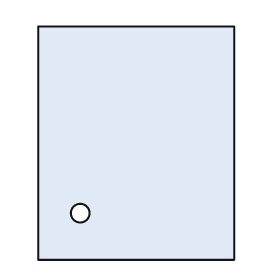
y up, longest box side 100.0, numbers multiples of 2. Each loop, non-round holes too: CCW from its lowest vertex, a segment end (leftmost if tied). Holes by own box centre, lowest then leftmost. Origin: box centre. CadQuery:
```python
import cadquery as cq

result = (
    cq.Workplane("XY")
    .moveTo(-42.0, -50.0)
    .lineTo(42.0, -50.0)
    .lineTo(42.0, 50.0)
    .lineTo(-42.0, 50.0)
    .close()
    .moveTo(-24.0, -30.0)
    .circle(4.0)
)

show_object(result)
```